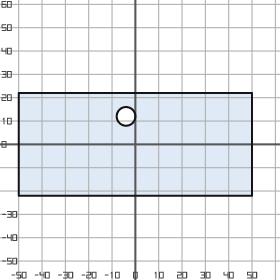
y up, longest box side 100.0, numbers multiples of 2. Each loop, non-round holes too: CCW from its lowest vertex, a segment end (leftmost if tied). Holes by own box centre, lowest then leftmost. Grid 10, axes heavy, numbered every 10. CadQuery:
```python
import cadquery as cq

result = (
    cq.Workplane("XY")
    .moveTo(-50.0, -22.0)
    .lineTo(50.0, -22.0)
    .lineTo(50.0, 22.0)
    .lineTo(-50.0, 22.0)
    .close()
    .moveTo(-4.0, 12.0)
    .circle(4.0)
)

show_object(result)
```